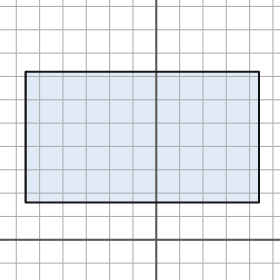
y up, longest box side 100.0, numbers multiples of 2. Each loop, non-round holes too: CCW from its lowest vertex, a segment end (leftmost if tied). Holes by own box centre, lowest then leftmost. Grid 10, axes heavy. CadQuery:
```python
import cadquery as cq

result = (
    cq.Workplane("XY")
    .moveTo(-56.0, 16.0)
    .lineTo(44.0, 16.0)
    .lineTo(44.0, 72.0)
    .lineTo(-56.0, 72.0)
    .close()
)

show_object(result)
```